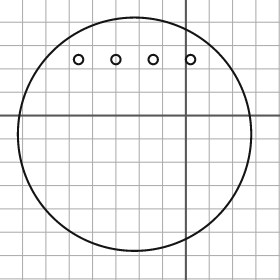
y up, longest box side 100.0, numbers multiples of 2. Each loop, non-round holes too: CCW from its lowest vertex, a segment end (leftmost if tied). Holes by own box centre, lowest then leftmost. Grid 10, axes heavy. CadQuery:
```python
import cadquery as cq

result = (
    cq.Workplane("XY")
    .moveTo(-22.0, -8.0)
    .circle(50.0)
    .moveTo(-46.0, 24.0)
    .circle(2.0)
    .moveTo(-30.0, 24.0)
    .circle(2.0)
    .moveTo(-14.0, 24.0)
    .circle(2.0)
    .moveTo(2.0, 24.0)
    .circle(2.0)
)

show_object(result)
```